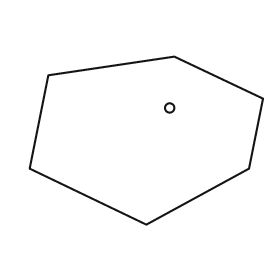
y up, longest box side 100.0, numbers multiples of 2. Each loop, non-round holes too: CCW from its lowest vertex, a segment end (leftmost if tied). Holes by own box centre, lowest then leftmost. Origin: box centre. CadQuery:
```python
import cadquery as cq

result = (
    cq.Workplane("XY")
    .moveTo(0.0, -36.0)
    .lineTo(44.0, -12.0)
    .lineTo(50.0, 18.0)
    .lineTo(12.0, 36.0)
    .lineTo(-42.0, 28.0)
    .lineTo(-50.0, -12.0)
    .close()
    .moveTo(10.0, 14.0)
    .circle(2.0)
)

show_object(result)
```